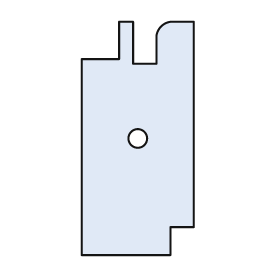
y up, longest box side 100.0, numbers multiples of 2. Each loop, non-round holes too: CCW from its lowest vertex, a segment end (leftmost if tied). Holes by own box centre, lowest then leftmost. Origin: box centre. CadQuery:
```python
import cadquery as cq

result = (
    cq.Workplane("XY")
    .moveTo(-24.0, -50.0)
    .lineTo(14.0, -50.0)
    .lineTo(14.0, -38.0)
    .lineTo(24.0, -38.0)
    .lineTo(24.0, 50.0)
    .lineTo(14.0, 50.0)
    .threePointArc((10.0, 48.0), (8.0, 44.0))
    .lineTo(8.0, 32.0)
    .lineTo(-2.0, 32.0)
    .lineTo(-2.0, 50.0)
    .lineTo(-8.0, 50.0)
    .lineTo(-8.0, 34.0)
    .lineTo(-24.0, 34.0)
    .close()
    .moveTo(0.0, 0.0)
    .circle(4.0)
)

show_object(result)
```